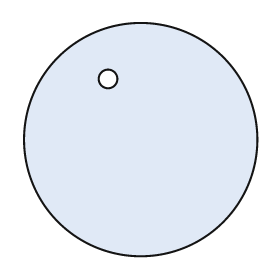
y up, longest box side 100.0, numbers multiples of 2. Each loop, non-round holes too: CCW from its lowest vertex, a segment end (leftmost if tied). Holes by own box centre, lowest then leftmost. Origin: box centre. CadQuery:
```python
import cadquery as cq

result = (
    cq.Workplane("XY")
    .moveTo(0.0, 0.0)
    .circle(50.0)
    .moveTo(-14.0, 26.0)
    .circle(4.0)
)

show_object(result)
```